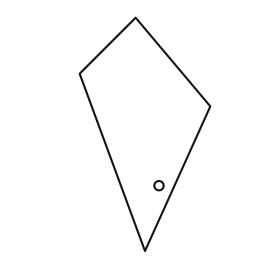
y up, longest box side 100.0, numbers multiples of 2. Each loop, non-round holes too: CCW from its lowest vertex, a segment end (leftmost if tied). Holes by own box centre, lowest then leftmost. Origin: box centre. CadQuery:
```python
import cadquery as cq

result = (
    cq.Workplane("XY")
    .moveTo(0.0, -50.0)
    .lineTo(28.0, 12.0)
    .lineTo(-4.0, 50.0)
    .lineTo(-28.0, 26.0)
    .close()
    .moveTo(6.0, -22.0)
    .circle(2.0)
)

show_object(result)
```